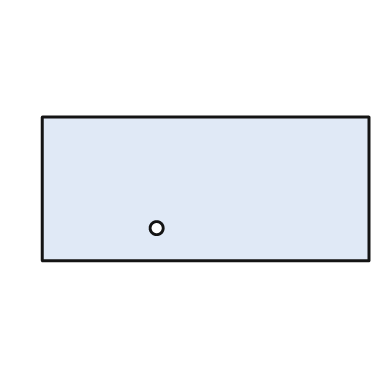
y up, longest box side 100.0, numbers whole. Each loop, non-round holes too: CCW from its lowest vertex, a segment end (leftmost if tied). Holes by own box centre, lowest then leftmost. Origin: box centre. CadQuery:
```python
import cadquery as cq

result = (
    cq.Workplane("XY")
    .moveTo(-50.0, -22.0)
    .lineTo(50.0, -22.0)
    .lineTo(50.0, 22.0)
    .lineTo(-50.0, 22.0)
    .close()
    .moveTo(-15.0, -12.0)
    .circle(2.0)
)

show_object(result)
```